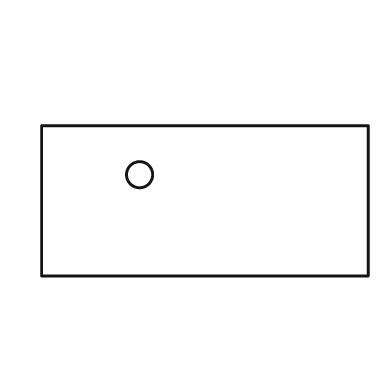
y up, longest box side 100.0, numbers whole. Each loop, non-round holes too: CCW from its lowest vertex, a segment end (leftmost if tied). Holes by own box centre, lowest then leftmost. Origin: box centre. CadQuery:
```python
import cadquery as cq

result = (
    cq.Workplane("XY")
    .moveTo(-50.0, -23.0)
    .lineTo(50.0, -23.0)
    .lineTo(50.0, 23.0)
    .lineTo(-50.0, 23.0)
    .close()
    .moveTo(-20.0, 8.0)
    .circle(4.0)
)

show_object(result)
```